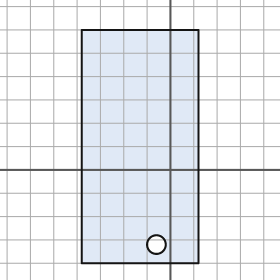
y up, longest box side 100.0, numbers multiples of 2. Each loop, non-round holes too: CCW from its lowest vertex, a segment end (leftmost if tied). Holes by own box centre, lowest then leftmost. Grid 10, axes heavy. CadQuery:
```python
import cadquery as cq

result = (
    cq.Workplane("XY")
    .moveTo(-38.0, -40.0)
    .lineTo(12.0, -40.0)
    .lineTo(12.0, 60.0)
    .lineTo(-38.0, 60.0)
    .close()
    .moveTo(-6.0, -32.0)
    .circle(4.0)
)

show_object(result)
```